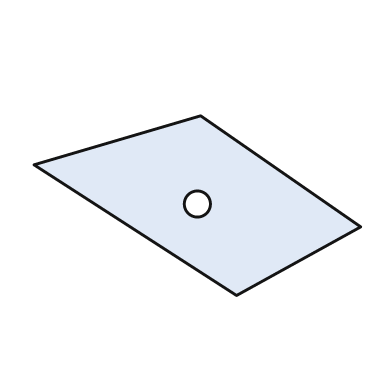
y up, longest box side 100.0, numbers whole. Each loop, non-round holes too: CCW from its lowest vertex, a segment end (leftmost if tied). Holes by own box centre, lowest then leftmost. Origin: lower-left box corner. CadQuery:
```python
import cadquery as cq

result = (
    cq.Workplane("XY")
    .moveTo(62.0, 0.0)
    .lineTo(100.0, 21.0)
    .lineTo(51.0, 55.0)
    .lineTo(0.0, 40.0)
    .close()
    .moveTo(50.0, 28.0)
    .circle(4.0)
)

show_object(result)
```